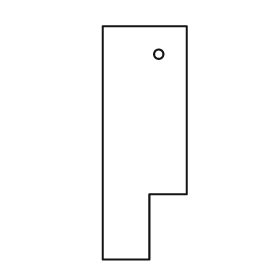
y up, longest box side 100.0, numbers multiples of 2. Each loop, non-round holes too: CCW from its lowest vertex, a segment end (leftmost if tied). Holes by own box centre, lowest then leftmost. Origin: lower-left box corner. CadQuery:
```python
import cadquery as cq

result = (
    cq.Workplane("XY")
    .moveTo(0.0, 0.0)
    .lineTo(20.0, 0.0)
    .lineTo(20.0, 28.0)
    .lineTo(36.0, 28.0)
    .lineTo(36.0, 100.0)
    .lineTo(0.0, 100.0)
    .close()
    .moveTo(24.0, 88.0)
    .circle(2.0)
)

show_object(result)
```